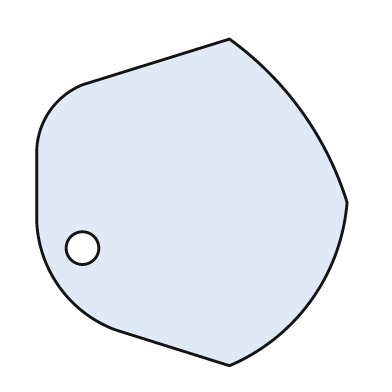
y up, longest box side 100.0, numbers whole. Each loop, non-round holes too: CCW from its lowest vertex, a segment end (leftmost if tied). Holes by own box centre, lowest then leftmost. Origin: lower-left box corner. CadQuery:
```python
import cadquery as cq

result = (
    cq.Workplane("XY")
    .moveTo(59.0, 0.0)
    .threePointArc((84.0, 20.0), (95.0, 50.0))
    .threePointArc((81.0, 78.0), (59.0, 100.0))
    .lineTo(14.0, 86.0)
    .threePointArc((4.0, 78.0), (0.0, 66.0))
    .lineTo(0.0, 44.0)
    .threePointArc((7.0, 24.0), (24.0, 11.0))
    .close()
    .moveTo(14.0, 36.0)
    .circle(5.0)
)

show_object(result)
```